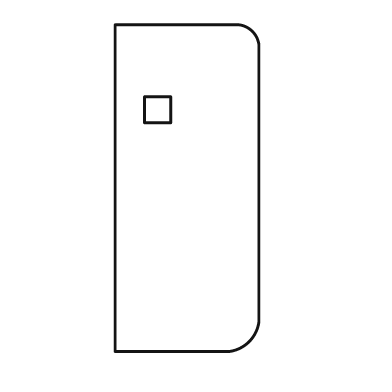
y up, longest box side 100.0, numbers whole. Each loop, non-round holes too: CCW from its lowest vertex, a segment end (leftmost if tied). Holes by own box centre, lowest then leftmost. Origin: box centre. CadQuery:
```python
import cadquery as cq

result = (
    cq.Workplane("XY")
    .moveTo(-22.0, -50.0)
    .lineTo(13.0, -50.0)
    .threePointArc((19.0, -47.0), (22.0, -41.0))
    .lineTo(22.0, 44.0)
    .threePointArc((20.0, 48.0), (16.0, 50.0))
    .lineTo(-22.0, 50.0)
    .close()
    .moveTo(-13.0, 20.0)
    .lineTo(-5.0, 20.0)
    .lineTo(-5.0, 28.0)
    .lineTo(-13.0, 28.0)
    .close()
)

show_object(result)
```